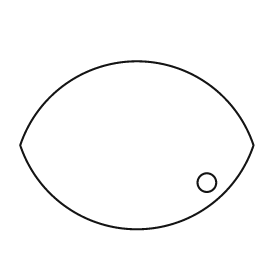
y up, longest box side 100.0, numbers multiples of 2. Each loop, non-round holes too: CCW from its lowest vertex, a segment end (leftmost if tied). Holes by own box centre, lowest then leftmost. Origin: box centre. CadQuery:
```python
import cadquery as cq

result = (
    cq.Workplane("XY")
    .moveTo(-50.0, 0.0)
    .threePointArc((0.0, -36.0), (50.0, 0.0))
    .threePointArc((0.0, 36.0), (-50.0, 0.0))
    .close()
    .moveTo(30.0, -16.0)
    .circle(4.0)
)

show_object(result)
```